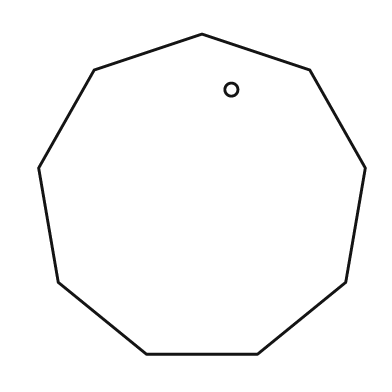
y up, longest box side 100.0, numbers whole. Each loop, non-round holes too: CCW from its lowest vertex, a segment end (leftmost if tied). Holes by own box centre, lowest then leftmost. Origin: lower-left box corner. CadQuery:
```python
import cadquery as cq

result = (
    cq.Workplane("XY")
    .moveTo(33.0, 0.0)
    .lineTo(67.0, 0.0)
    .lineTo(94.0, 22.0)
    .lineTo(100.0, 57.0)
    .lineTo(83.0, 87.0)
    .lineTo(50.0, 98.0)
    .lineTo(17.0, 87.0)
    .lineTo(0.0, 57.0)
    .lineTo(6.0, 22.0)
    .close()
    .moveTo(59.0, 81.0)
    .circle(2.0)
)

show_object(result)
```